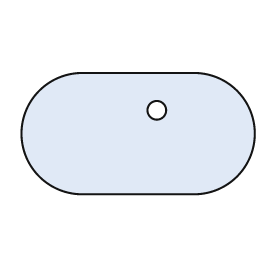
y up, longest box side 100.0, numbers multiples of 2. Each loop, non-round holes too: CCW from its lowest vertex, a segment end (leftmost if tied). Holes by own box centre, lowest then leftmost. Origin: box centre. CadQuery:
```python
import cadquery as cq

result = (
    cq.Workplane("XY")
    .moveTo(-24.0, -26.0)
    .lineTo(24.0, -26.0)
    .threePointArc((50.0, 0.0), (24.0, 26.0))
    .lineTo(-24.0, 26.0)
    .threePointArc((-50.0, 0.0), (-24.0, -26.0))
    .close()
    .moveTo(8.0, 10.0)
    .circle(4.0)
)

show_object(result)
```